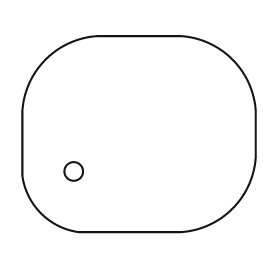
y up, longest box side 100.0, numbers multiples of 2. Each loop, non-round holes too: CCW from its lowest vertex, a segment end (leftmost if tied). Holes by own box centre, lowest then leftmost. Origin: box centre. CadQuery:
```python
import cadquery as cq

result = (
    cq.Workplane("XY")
    .moveTo(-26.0, -42.0)
    .lineTo(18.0, -42.0)
    .threePointArc((40.0, -32.0), (50.0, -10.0))
    .lineTo(50.0, 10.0)
    .threePointArc((40.0, 32.0), (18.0, 42.0))
    .lineTo(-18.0, 42.0)
    .threePointArc((-40.0, 32.0), (-50.0, 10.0))
    .lineTo(-50.0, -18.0)
    .threePointArc((-42.0, -34.0), (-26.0, -42.0))
    .close()
    .moveTo(-28.0, -16.0)
    .circle(4.0)
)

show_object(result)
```